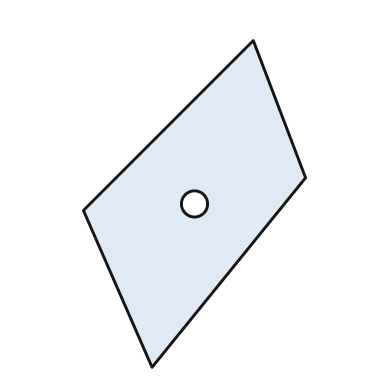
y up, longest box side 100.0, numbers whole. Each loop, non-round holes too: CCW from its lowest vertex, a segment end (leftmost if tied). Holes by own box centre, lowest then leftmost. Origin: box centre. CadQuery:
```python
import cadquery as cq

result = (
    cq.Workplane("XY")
    .moveTo(-13.0, -50.0)
    .lineTo(34.0, 8.0)
    .lineTo(18.0, 50.0)
    .lineTo(-34.0, -2.0)
    .close()
    .moveTo(0.0, 0.0)
    .circle(4.0)
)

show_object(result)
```